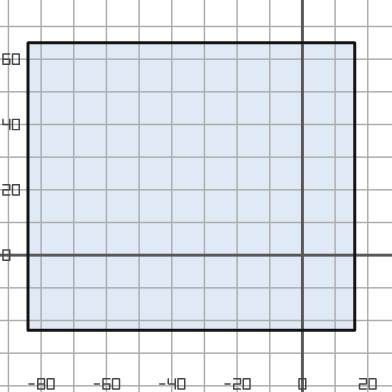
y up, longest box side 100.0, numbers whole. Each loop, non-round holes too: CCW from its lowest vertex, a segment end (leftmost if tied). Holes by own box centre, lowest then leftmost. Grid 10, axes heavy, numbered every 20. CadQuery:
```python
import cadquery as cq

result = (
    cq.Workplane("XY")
    .moveTo(-84.0, -23.0)
    .lineTo(16.0, -23.0)
    .lineTo(16.0, 65.0)
    .lineTo(-84.0, 65.0)
    .close()
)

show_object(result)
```